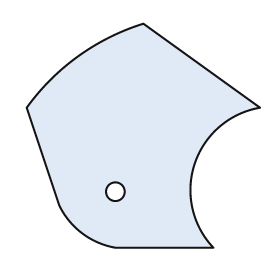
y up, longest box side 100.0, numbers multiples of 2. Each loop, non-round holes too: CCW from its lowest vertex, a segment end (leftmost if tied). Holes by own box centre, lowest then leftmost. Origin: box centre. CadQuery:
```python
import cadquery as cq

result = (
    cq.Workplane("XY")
    .moveTo(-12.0, -48.0)
    .lineTo(30.0, -48.0)
    .threePointArc((22.0, -12.0), (50.0, 12.0))
    .lineTo(0.0, 48.0)
    .threePointArc((-28.0, 34.0), (-50.0, 12.0))
    .lineTo(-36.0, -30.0)
    .threePointArc((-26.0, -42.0), (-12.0, -48.0))
    .close()
    .moveTo(-12.0, -24.0)
    .circle(4.0)
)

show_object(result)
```